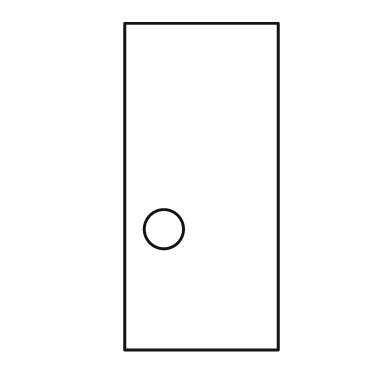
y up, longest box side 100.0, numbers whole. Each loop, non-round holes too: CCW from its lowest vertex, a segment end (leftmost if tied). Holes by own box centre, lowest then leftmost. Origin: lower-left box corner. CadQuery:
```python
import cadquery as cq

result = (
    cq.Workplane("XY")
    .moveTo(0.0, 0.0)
    .lineTo(47.0, 0.0)
    .lineTo(47.0, 100.0)
    .lineTo(0.0, 100.0)
    .close()
    .moveTo(12.0, 37.0)
    .circle(6.0)
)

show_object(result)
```